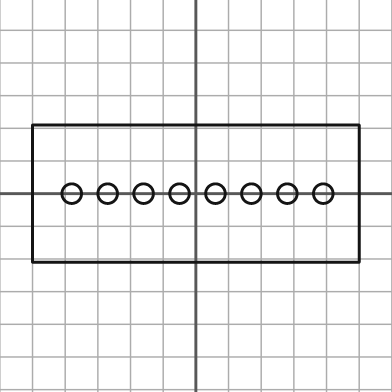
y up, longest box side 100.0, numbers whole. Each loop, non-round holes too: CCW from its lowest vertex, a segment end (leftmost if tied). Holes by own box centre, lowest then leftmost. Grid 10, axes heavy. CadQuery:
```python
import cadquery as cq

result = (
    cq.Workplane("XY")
    .moveTo(-50.0, -21.0)
    .lineTo(50.0, -21.0)
    .lineTo(50.0, 21.0)
    .lineTo(-50.0, 21.0)
    .close()
    .moveTo(-38.0, 0.0)
    .circle(3.0)
    .moveTo(-27.0, 0.0)
    .circle(3.0)
    .moveTo(-16.0, 0.0)
    .circle(3.0)
    .moveTo(-5.0, 0.0)
    .circle(3.0)
    .moveTo(6.0, 0.0)
    .circle(3.0)
    .moveTo(17.0, 0.0)
    .circle(3.0)
    .moveTo(28.0, 0.0)
    .circle(3.0)
    .moveTo(39.0, 0.0)
    .circle(3.0)
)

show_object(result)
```